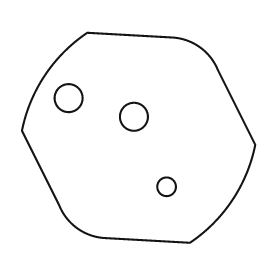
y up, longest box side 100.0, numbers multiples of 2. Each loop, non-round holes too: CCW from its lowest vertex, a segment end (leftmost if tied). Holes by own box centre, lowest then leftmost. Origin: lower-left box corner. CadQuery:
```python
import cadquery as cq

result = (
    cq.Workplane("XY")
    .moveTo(72.0, 0.0)
    .threePointArc((90.0, 18.0), (100.0, 42.0))
    .lineTo(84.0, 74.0)
    .threePointArc((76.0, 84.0), (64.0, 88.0))
    .lineTo(28.0, 90.0)
    .threePointArc((10.0, 72.0), (0.0, 48.0))
    .lineTo(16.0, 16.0)
    .threePointArc((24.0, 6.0), (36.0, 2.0))
    .close()
    .moveTo(62.0, 24.0)
    .circle(4.0)
    .moveTo(48.0, 54.0)
    .circle(6.0)
    .moveTo(20.0, 62.0)
    .circle(6.0)
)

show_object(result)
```